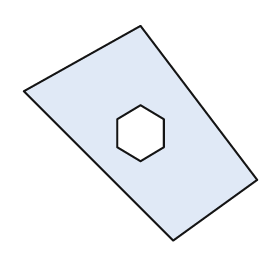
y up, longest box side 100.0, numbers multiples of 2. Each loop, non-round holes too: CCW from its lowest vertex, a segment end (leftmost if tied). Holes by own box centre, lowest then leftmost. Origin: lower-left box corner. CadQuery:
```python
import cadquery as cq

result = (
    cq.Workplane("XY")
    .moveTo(64.0, 0.0)
    .lineTo(100.0, 26.0)
    .lineTo(50.0, 92.0)
    .lineTo(0.0, 64.0)
    .close()
    .moveTo(50.0, 34.0)
    .lineTo(60.0, 40.0)
    .lineTo(60.0, 52.0)
    .lineTo(50.0, 58.0)
    .lineTo(40.0, 52.0)
    .lineTo(40.0, 40.0)
    .close()
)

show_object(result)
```